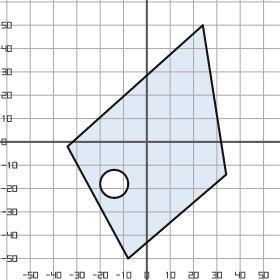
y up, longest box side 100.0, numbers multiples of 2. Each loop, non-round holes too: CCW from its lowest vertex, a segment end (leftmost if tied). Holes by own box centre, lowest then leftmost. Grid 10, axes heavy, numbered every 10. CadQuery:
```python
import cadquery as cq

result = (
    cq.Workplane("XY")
    .moveTo(-8.0, -50.0)
    .lineTo(34.0, -14.0)
    .lineTo(24.0, 50.0)
    .lineTo(-34.0, -2.0)
    .close()
    .moveTo(-14.0, -18.0)
    .circle(6.0)
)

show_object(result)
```